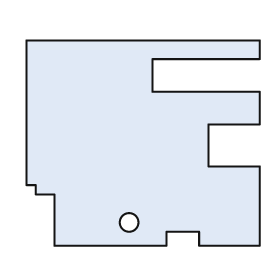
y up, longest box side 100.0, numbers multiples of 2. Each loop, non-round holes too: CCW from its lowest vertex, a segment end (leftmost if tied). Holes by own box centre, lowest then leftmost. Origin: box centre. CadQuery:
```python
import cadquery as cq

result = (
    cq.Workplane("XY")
    .moveTo(-38.0, -44.0)
    .lineTo(10.0, -44.0)
    .lineTo(10.0, -38.0)
    .lineTo(24.0, -38.0)
    .lineTo(24.0, -44.0)
    .lineTo(50.0, -44.0)
    .lineTo(50.0, -10.0)
    .lineTo(28.0, -10.0)
    .lineTo(28.0, 8.0)
    .lineTo(50.0, 8.0)
    .lineTo(50.0, 22.0)
    .lineTo(4.0, 22.0)
    .lineTo(4.0, 36.0)
    .lineTo(50.0, 36.0)
    .lineTo(50.0, 44.0)
    .lineTo(-50.0, 44.0)
    .lineTo(-50.0, -18.0)
    .lineTo(-46.0, -18.0)
    .lineTo(-46.0, -22.0)
    .lineTo(-38.0, -22.0)
    .close()
    .moveTo(-6.0, -34.0)
    .circle(4.0)
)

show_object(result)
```